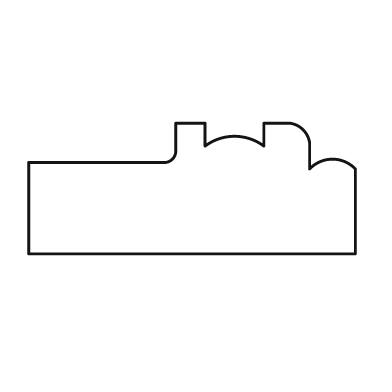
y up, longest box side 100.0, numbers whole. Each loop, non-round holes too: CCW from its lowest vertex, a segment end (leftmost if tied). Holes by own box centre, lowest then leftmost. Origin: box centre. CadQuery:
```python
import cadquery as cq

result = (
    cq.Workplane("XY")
    .moveTo(-50.0, -20.0)
    .lineTo(50.0, -20.0)
    .lineTo(50.0, 6.0)
    .threePointArc((43.0, 9.0), (36.0, 6.0))
    .lineTo(36.0, 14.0)
    .threePointArc((34.0, 18.0), (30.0, 20.0))
    .lineTo(22.0, 20.0)
    .lineTo(22.0, 13.0)
    .threePointArc((13.0, 16.0), (4.0, 13.0))
    .lineTo(4.0, 20.0)
    .lineTo(-5.0, 20.0)
    .lineTo(-5.0, 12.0)
    .threePointArc((-6.0, 9.0), (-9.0, 8.0))
    .lineTo(-50.0, 8.0)
    .close()
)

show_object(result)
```